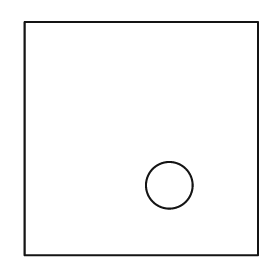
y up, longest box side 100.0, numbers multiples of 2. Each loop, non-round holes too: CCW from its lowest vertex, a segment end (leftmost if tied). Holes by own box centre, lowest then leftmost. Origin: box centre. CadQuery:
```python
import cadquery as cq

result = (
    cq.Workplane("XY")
    .moveTo(-50.0, -50.0)
    .lineTo(50.0, -50.0)
    .lineTo(50.0, 50.0)
    .lineTo(-50.0, 50.0)
    .close()
    .moveTo(12.0, -20.0)
    .circle(10.0)
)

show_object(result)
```